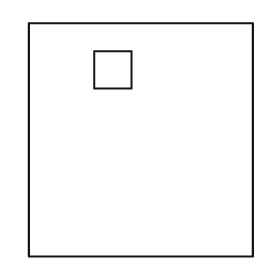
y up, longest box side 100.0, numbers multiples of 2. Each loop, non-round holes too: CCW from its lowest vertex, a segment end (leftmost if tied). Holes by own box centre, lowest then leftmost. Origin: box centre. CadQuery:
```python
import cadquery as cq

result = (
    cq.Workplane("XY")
    .moveTo(-48.0, -50.0)
    .lineTo(48.0, -50.0)
    .lineTo(48.0, 50.0)
    .lineTo(-48.0, 50.0)
    .close()
    .moveTo(-20.0, 22.0)
    .lineTo(-4.0, 22.0)
    .lineTo(-4.0, 38.0)
    .lineTo(-20.0, 38.0)
    .close()
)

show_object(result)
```